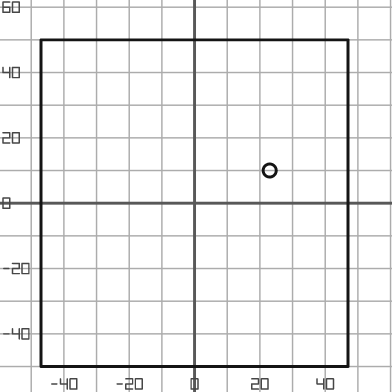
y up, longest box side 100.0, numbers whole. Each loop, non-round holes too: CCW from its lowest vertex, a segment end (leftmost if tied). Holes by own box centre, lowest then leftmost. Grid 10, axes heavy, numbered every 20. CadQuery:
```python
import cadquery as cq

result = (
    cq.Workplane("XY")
    .moveTo(-47.0, -50.0)
    .lineTo(47.0, -50.0)
    .lineTo(47.0, 50.0)
    .lineTo(-47.0, 50.0)
    .close()
    .moveTo(23.0, 10.0)
    .circle(2.0)
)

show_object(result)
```